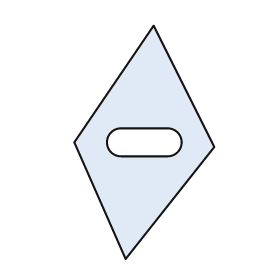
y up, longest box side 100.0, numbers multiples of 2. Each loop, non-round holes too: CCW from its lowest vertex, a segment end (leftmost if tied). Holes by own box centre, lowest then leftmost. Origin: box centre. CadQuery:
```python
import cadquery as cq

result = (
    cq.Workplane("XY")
    .moveTo(-8.0, -50.0)
    .lineTo(30.0, -2.0)
    .lineTo(4.0, 50.0)
    .lineTo(-30.0, 0.0)
    .close()
    .moveTo(-10.0, -6.0)
    .lineTo(10.0, -6.0)
    .threePointArc((16.0, 0.0), (10.0, 6.0))
    .lineTo(-10.0, 6.0)
    .threePointArc((-16.0, 0.0), (-10.0, -6.0))
    .close()
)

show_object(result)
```